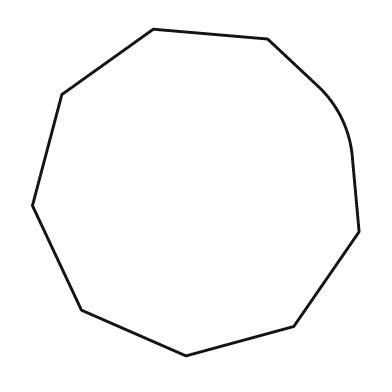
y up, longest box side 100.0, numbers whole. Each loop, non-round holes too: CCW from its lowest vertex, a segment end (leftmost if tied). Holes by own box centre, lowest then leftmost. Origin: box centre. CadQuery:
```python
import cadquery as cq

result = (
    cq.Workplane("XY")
    .moveTo(-3.0, -50.0)
    .lineTo(30.0, -41.0)
    .lineTo(50.0, -12.0)
    .lineTo(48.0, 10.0)
    .threePointArc((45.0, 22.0), (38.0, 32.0))
    .lineTo(22.0, 47.0)
    .lineTo(-13.0, 50.0)
    .lineTo(-41.0, 30.0)
    .lineTo(-50.0, -4.0)
    .lineTo(-35.0, -36.0)
    .close()
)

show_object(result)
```